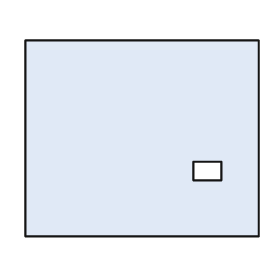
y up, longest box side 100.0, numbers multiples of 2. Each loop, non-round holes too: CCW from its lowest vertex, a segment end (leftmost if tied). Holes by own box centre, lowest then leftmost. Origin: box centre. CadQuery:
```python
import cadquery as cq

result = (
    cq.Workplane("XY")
    .moveTo(-50.0, -42.0)
    .lineTo(50.0, -42.0)
    .lineTo(50.0, 42.0)
    .lineTo(-50.0, 42.0)
    .close()
    .moveTo(22.0, -18.0)
    .lineTo(34.0, -18.0)
    .lineTo(34.0, -10.0)
    .lineTo(22.0, -10.0)
    .close()
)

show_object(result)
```